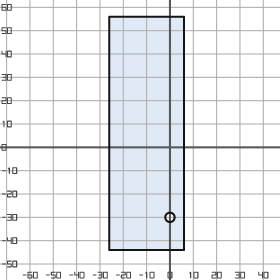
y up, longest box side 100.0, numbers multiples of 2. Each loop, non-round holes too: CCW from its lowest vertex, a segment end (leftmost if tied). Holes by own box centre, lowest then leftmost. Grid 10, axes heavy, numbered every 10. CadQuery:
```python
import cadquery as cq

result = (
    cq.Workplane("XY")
    .moveTo(-26.0, -44.0)
    .lineTo(6.0, -44.0)
    .lineTo(6.0, 56.0)
    .lineTo(-26.0, 56.0)
    .close()
    .moveTo(0.0, -30.0)
    .circle(2.0)
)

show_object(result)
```